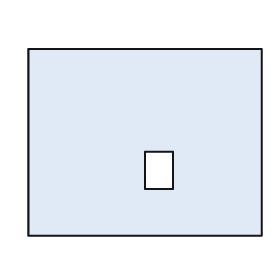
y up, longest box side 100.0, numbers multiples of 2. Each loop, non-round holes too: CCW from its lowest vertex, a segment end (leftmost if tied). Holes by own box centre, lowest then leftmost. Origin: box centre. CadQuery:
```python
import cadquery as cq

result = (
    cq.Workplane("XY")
    .moveTo(-50.0, -40.0)
    .lineTo(50.0, -40.0)
    .lineTo(50.0, 40.0)
    .lineTo(-50.0, 40.0)
    .close()
    .moveTo(0.0, -20.0)
    .lineTo(12.0, -20.0)
    .lineTo(12.0, -4.0)
    .lineTo(0.0, -4.0)
    .close()
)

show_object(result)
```